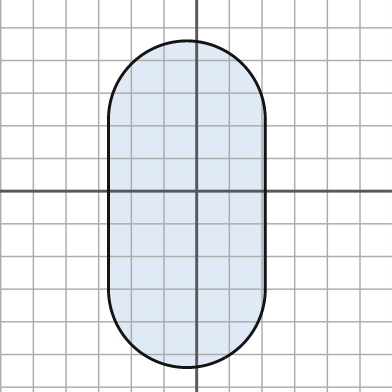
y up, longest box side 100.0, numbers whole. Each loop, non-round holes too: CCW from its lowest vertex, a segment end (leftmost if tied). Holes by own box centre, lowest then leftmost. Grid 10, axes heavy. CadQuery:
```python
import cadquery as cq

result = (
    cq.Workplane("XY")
    .moveTo(-27.0, -30.0)
    .threePointArc((-3.0, -54.0), (21.0, -30.0))
    .lineTo(21.0, 22.0)
    .threePointArc((-3.0, 46.0), (-27.0, 22.0))
    .close()
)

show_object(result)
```